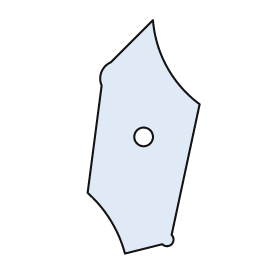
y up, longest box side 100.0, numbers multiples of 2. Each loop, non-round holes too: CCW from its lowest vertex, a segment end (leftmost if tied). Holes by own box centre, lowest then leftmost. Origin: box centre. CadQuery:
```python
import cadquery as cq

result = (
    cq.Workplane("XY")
    .moveTo(-8.0, -50.0)
    .lineTo(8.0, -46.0)
    .threePointArc((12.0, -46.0), (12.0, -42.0))
    .lineTo(24.0, 14.0)
    .threePointArc((10.0, 30.0), (4.0, 50.0))
    .lineTo(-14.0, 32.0)
    .threePointArc((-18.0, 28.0), (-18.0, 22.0))
    .lineTo(-24.0, -24.0)
    .threePointArc((-14.0, -36.0), (-8.0, -50.0))
    .close()
    .moveTo(0.0, 0.0)
    .circle(4.0)
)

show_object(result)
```